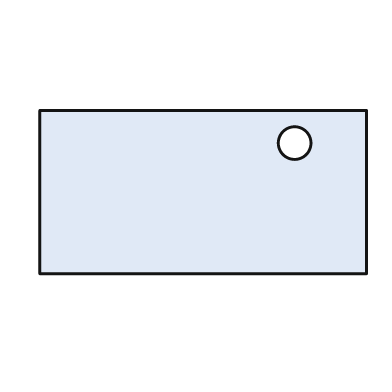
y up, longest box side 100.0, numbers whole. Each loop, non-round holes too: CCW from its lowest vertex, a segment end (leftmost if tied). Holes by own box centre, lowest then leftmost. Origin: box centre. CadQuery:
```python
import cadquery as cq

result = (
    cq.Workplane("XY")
    .moveTo(-50.0, -25.0)
    .lineTo(50.0, -25.0)
    .lineTo(50.0, 25.0)
    .lineTo(-50.0, 25.0)
    .close()
    .moveTo(28.0, 15.0)
    .circle(5.0)
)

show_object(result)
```